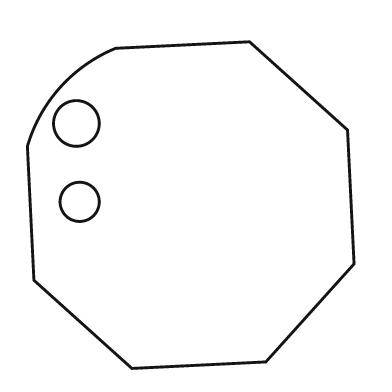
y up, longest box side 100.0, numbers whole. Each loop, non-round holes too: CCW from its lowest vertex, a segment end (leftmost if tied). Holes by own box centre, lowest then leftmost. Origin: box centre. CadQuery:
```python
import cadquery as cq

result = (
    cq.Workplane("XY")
    .moveTo(-18.0, -50.0)
    .lineTo(23.0, -48.0)
    .lineTo(50.0, -18.0)
    .lineTo(48.0, 23.0)
    .lineTo(18.0, 50.0)
    .lineTo(-23.0, 48.0)
    .threePointArc((-40.0, 36.0), (-50.0, 18.0))
    .lineTo(-48.0, -23.0)
    .close()
    .moveTo(-34.0, 1.0)
    .circle(6.0)
    .moveTo(-35.0, 25.0)
    .circle(7.0)
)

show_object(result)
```